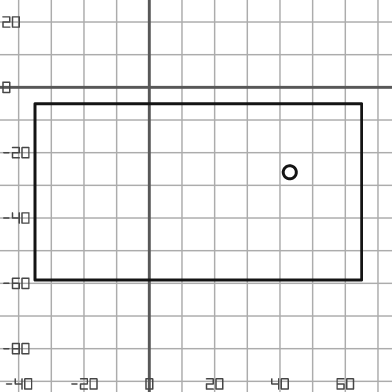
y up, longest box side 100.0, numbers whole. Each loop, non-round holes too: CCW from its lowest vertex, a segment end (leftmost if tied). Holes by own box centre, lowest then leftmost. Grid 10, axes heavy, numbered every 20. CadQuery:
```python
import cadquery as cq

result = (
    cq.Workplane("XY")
    .moveTo(-35.0, -59.0)
    .lineTo(65.0, -59.0)
    .lineTo(65.0, -5.0)
    .lineTo(-35.0, -5.0)
    .close()
    .moveTo(43.0, -26.0)
    .circle(2.0)
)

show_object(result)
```